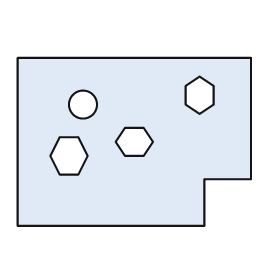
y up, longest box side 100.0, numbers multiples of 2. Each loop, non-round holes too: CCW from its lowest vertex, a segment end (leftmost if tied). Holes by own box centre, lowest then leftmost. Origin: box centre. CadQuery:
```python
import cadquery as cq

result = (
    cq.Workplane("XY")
    .moveTo(-50.0, -36.0)
    .lineTo(30.0, -36.0)
    .lineTo(30.0, -16.0)
    .lineTo(50.0, -16.0)
    .lineTo(50.0, 36.0)
    .lineTo(-50.0, 36.0)
    .close()
    .moveTo(-32.0, -14.0)
    .lineTo(-24.0, -14.0)
    .lineTo(-20.0, -6.0)
    .lineTo(-24.0, 2.0)
    .lineTo(-32.0, 2.0)
    .lineTo(-36.0, -6.0)
    .close()
    .moveTo(-4.0, -6.0)
    .lineTo(4.0, -6.0)
    .lineTo(8.0, 0.0)
    .lineTo(4.0, 6.0)
    .lineTo(-4.0, 6.0)
    .lineTo(-8.0, 0.0)
    .close()
    .moveTo(-22.0, 16.0)
    .circle(6.0)
    .moveTo(28.0, 12.0)
    .lineTo(34.0, 16.0)
    .lineTo(34.0, 24.0)
    .lineTo(28.0, 28.0)
    .lineTo(22.0, 24.0)
    .lineTo(22.0, 16.0)
    .close()
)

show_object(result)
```